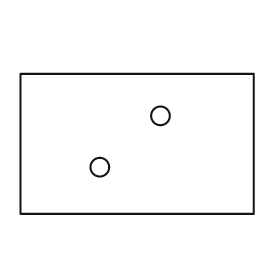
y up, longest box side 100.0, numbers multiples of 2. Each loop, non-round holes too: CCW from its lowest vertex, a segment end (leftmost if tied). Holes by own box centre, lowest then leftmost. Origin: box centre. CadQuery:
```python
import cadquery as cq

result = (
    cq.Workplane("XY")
    .moveTo(-50.0, -30.0)
    .lineTo(50.0, -30.0)
    .lineTo(50.0, 30.0)
    .lineTo(-50.0, 30.0)
    .close()
    .moveTo(-16.0, -10.0)
    .circle(4.0)
    .moveTo(10.0, 12.0)
    .circle(4.0)
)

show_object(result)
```